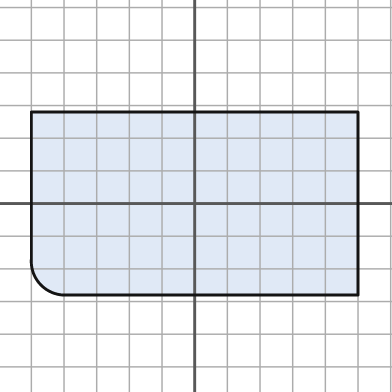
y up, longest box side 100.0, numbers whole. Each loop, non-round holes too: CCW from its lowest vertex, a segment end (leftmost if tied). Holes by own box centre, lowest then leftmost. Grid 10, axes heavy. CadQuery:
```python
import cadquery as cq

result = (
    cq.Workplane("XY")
    .moveTo(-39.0, -28.0)
    .lineTo(50.0, -28.0)
    .lineTo(50.0, 28.0)
    .lineTo(-50.0, 28.0)
    .lineTo(-50.0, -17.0)
    .threePointArc((-47.0, -25.0), (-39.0, -28.0))
    .close()
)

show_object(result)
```